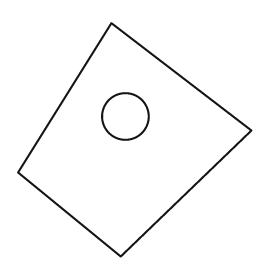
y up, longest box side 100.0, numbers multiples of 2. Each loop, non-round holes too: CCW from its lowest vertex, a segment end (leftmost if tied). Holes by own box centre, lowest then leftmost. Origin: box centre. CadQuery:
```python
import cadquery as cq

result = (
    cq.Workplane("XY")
    .moveTo(-6.0, -50.0)
    .lineTo(50.0, 4.0)
    .lineTo(-10.0, 50.0)
    .lineTo(-50.0, -14.0)
    .close()
    .moveTo(-4.0, 10.0)
    .circle(10.0)
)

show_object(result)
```